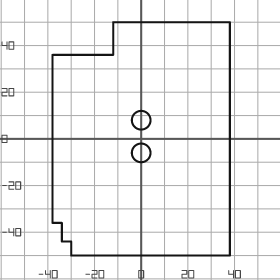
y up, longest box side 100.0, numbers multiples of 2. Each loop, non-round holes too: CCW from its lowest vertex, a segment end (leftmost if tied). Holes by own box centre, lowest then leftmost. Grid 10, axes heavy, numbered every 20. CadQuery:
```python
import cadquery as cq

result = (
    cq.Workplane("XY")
    .moveTo(-30.0, -50.0)
    .lineTo(38.0, -50.0)
    .lineTo(38.0, 50.0)
    .lineTo(-12.0, 50.0)
    .lineTo(-12.0, 36.0)
    .lineTo(-38.0, 36.0)
    .lineTo(-38.0, -36.0)
    .lineTo(-34.0, -36.0)
    .lineTo(-34.0, -44.0)
    .lineTo(-30.0, -44.0)
    .close()
    .moveTo(0.0, -6.0)
    .circle(4.0)
    .moveTo(0.0, 8.0)
    .circle(4.0)
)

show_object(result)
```